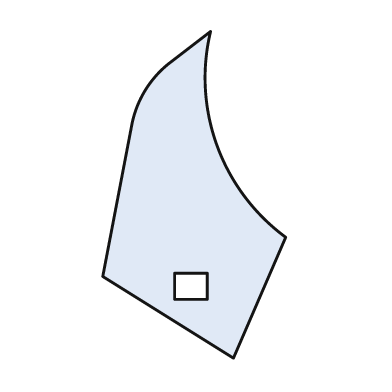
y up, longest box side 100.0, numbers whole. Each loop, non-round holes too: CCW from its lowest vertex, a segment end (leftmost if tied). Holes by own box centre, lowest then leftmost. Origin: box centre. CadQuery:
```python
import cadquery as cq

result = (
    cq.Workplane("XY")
    .moveTo(12.0, -50.0)
    .lineTo(28.0, -13.0)
    .threePointArc((7.0, 15.0), (5.0, 50.0))
    .lineTo(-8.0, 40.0)
    .threePointArc((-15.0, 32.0), (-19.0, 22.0))
    .lineTo(-28.0, -25.0)
    .close()
    .moveTo(-6.0, -32.0)
    .lineTo(4.0, -32.0)
    .lineTo(4.0, -24.0)
    .lineTo(-6.0, -24.0)
    .close()
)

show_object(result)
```